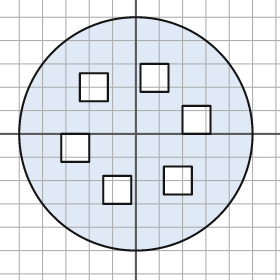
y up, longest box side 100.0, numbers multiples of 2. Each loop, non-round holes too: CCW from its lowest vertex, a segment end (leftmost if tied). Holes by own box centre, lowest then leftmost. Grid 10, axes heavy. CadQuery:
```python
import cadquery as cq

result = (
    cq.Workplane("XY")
    .moveTo(0.0, 0.0)
    .circle(50.0)
    .moveTo(-14.0, -30.0)
    .lineTo(-2.0, -30.0)
    .lineTo(-2.0, -18.0)
    .lineTo(-14.0, -18.0)
    .close()
    .moveTo(12.0, -26.0)
    .lineTo(24.0, -26.0)
    .lineTo(24.0, -14.0)
    .lineTo(12.0, -14.0)
    .close()
    .moveTo(-32.0, -12.0)
    .lineTo(-20.0, -12.0)
    .lineTo(-20.0, 0.0)
    .lineTo(-32.0, 0.0)
    .close()
    .moveTo(20.0, 0.0)
    .lineTo(32.0, 0.0)
    .lineTo(32.0, 12.0)
    .lineTo(20.0, 12.0)
    .close()
    .moveTo(-24.0, 14.0)
    .lineTo(-12.0, 14.0)
    .lineTo(-12.0, 26.0)
    .lineTo(-24.0, 26.0)
    .close()
    .moveTo(2.0, 18.0)
    .lineTo(14.0, 18.0)
    .lineTo(14.0, 30.0)
    .lineTo(2.0, 30.0)
    .close()
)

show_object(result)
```